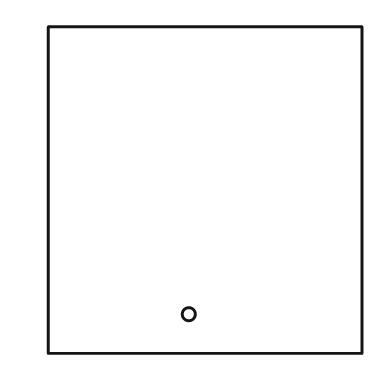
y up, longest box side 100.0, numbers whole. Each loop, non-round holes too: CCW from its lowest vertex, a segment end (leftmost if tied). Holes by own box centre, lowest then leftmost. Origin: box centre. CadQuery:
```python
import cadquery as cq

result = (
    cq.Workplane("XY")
    .moveTo(-48.0, -50.0)
    .lineTo(48.0, -50.0)
    .lineTo(48.0, 50.0)
    .lineTo(-48.0, 50.0)
    .close()
    .moveTo(-5.0, -38.0)
    .circle(2.0)
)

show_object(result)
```